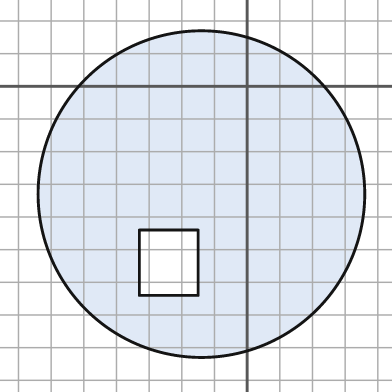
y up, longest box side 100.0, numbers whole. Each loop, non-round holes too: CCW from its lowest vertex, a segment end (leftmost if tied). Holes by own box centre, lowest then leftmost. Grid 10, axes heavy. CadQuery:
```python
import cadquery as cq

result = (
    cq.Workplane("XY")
    .moveTo(-14.0, -33.0)
    .circle(50.0)
    .moveTo(-33.0, -64.0)
    .lineTo(-15.0, -64.0)
    .lineTo(-15.0, -44.0)
    .lineTo(-33.0, -44.0)
    .close()
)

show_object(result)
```